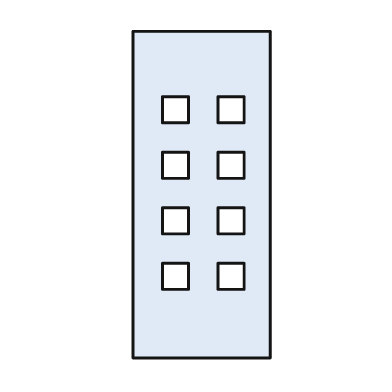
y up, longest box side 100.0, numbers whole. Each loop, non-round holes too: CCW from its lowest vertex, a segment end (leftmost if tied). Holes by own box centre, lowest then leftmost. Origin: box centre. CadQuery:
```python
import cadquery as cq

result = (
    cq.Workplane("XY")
    .moveTo(-21.0, -50.0)
    .lineTo(21.0, -50.0)
    .lineTo(21.0, 50.0)
    .lineTo(-21.0, 50.0)
    .close()
    .moveTo(-12.0, -29.0)
    .lineTo(-4.0, -29.0)
    .lineTo(-4.0, -21.0)
    .lineTo(-12.0, -21.0)
    .close()
    .moveTo(5.0, -29.0)
    .lineTo(13.0, -29.0)
    .lineTo(13.0, -21.0)
    .lineTo(5.0, -21.0)
    .close()
    .moveTo(-12.0, -12.0)
    .lineTo(-4.0, -12.0)
    .lineTo(-4.0, -4.0)
    .lineTo(-12.0, -4.0)
    .close()
    .moveTo(5.0, -12.0)
    .lineTo(13.0, -12.0)
    .lineTo(13.0, -4.0)
    .lineTo(5.0, -4.0)
    .close()
    .moveTo(-12.0, 5.0)
    .lineTo(-4.0, 5.0)
    .lineTo(-4.0, 13.0)
    .lineTo(-12.0, 13.0)
    .close()
    .moveTo(5.0, 5.0)
    .lineTo(13.0, 5.0)
    .lineTo(13.0, 13.0)
    .lineTo(5.0, 13.0)
    .close()
    .moveTo(-12.0, 22.0)
    .lineTo(-4.0, 22.0)
    .lineTo(-4.0, 30.0)
    .lineTo(-12.0, 30.0)
    .close()
    .moveTo(5.0, 22.0)
    .lineTo(13.0, 22.0)
    .lineTo(13.0, 30.0)
    .lineTo(5.0, 30.0)
    .close()
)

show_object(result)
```